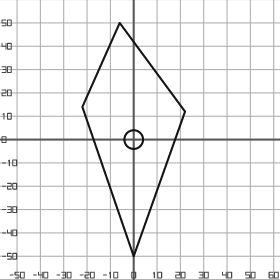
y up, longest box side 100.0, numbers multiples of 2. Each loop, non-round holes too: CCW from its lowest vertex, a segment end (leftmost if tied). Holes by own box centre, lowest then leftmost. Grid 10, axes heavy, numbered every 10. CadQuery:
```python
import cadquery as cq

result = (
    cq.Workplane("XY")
    .moveTo(0.0, -50.0)
    .lineTo(22.0, 12.0)
    .lineTo(-6.0, 50.0)
    .lineTo(-22.0, 14.0)
    .close()
    .moveTo(0.0, 0.0)
    .circle(4.0)
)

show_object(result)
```